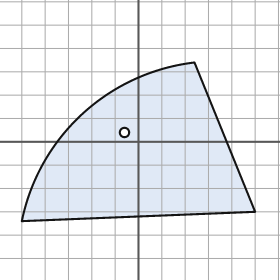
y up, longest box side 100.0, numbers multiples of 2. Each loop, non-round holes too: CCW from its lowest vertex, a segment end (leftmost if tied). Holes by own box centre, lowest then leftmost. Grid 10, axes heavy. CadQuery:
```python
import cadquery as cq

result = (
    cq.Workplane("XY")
    .moveTo(-50.0, -34.0)
    .lineTo(50.0, -30.0)
    .lineTo(24.0, 34.0)
    .threePointArc((-24.0, 12.0), (-50.0, -34.0))
    .close()
    .moveTo(-6.0, 4.0)
    .circle(2.0)
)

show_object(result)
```